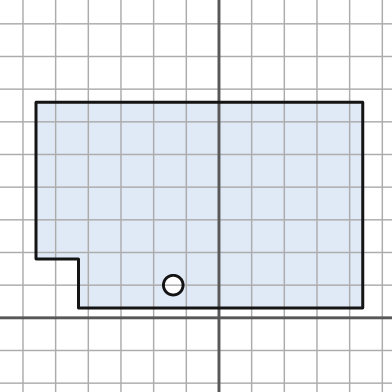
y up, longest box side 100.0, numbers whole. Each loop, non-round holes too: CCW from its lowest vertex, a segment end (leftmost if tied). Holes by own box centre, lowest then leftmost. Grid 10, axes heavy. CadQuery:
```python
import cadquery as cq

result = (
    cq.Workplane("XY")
    .moveTo(-43.0, 3.0)
    .lineTo(44.0, 3.0)
    .lineTo(44.0, 66.0)
    .lineTo(-56.0, 66.0)
    .lineTo(-56.0, 18.0)
    .lineTo(-43.0, 18.0)
    .close()
    .moveTo(-14.0, 10.0)
    .circle(3.0)
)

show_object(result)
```